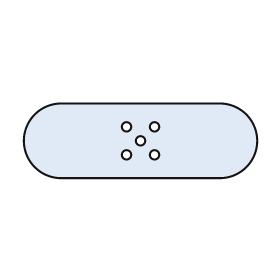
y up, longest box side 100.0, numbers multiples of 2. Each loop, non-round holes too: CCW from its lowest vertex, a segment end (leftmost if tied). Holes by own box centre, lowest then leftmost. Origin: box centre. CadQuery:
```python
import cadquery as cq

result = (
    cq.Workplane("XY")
    .moveTo(-34.0, -16.0)
    .lineTo(34.0, -16.0)
    .threePointArc((50.0, 0.0), (34.0, 16.0))
    .lineTo(-34.0, 16.0)
    .threePointArc((-50.0, 0.0), (-34.0, -16.0))
    .close()
    .moveTo(-6.0, -6.0)
    .circle(2.0)
    .moveTo(6.0, -6.0)
    .circle(2.0)
    .moveTo(0.0, 0.0)
    .circle(2.0)
    .moveTo(-6.0, 6.0)
    .circle(2.0)
    .moveTo(6.0, 6.0)
    .circle(2.0)
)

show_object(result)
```